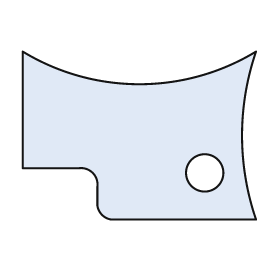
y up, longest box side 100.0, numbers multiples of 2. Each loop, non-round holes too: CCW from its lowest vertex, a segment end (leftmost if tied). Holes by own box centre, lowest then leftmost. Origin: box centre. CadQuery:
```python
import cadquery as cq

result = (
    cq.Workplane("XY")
    .moveTo(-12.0, -36.0)
    .lineTo(50.0, -36.0)
    .threePointArc((44.0, 0.0), (50.0, 36.0))
    .threePointArc((0.0, 22.0), (-50.0, 36.0))
    .lineTo(-50.0, -14.0)
    .lineTo(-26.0, -14.0)
    .threePointArc((-20.0, -16.0), (-18.0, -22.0))
    .lineTo(-18.0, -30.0)
    .threePointArc((-16.0, -34.0), (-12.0, -36.0))
    .close()
    .moveTo(28.0, -16.0)
    .circle(8.0)
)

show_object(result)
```